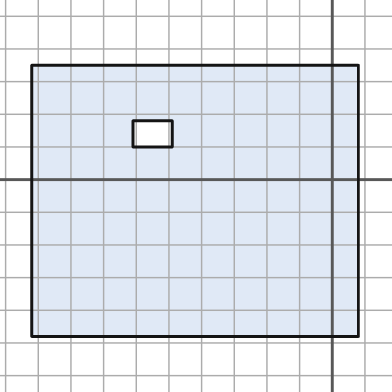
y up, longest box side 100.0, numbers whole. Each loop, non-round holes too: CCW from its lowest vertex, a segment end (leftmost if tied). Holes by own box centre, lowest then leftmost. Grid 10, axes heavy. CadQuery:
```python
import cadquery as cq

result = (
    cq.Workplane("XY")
    .moveTo(-92.0, -48.0)
    .lineTo(8.0, -48.0)
    .lineTo(8.0, 35.0)
    .lineTo(-92.0, 35.0)
    .close()
    .moveTo(-61.0, 10.0)
    .lineTo(-49.0, 10.0)
    .lineTo(-49.0, 18.0)
    .lineTo(-61.0, 18.0)
    .close()
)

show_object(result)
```